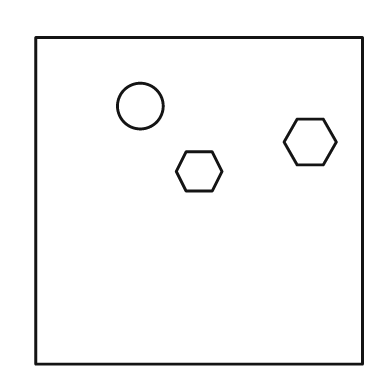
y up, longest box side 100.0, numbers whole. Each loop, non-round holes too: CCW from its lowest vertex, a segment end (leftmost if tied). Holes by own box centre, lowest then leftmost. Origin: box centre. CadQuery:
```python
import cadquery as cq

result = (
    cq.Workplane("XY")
    .moveTo(-50.0, -50.0)
    .lineTo(50.0, -50.0)
    .lineTo(50.0, 50.0)
    .lineTo(-50.0, 50.0)
    .close()
    .moveTo(-4.0, 3.0)
    .lineTo(4.0, 3.0)
    .lineTo(7.0, 9.0)
    .lineTo(4.0, 15.0)
    .lineTo(-4.0, 15.0)
    .lineTo(-7.0, 9.0)
    .close()
    .moveTo(30.0, 11.0)
    .lineTo(38.0, 11.0)
    .lineTo(42.0, 18.0)
    .lineTo(38.0, 25.0)
    .lineTo(30.0, 25.0)
    .lineTo(26.0, 18.0)
    .close()
    .moveTo(-18.0, 29.0)
    .circle(7.0)
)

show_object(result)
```